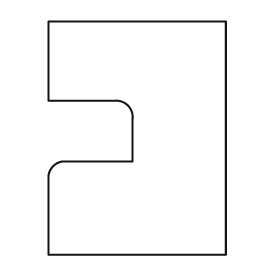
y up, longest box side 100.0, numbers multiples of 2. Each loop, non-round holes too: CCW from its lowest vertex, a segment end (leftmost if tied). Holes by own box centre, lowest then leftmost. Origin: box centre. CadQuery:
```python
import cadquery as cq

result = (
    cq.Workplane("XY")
    .moveTo(-38.0, -50.0)
    .lineTo(38.0, -50.0)
    .lineTo(38.0, 50.0)
    .lineTo(-38.0, 50.0)
    .lineTo(-38.0, 16.0)
    .lineTo(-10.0, 16.0)
    .threePointArc((-4.0, 14.0), (-2.0, 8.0))
    .lineTo(-2.0, -10.0)
    .lineTo(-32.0, -10.0)
    .threePointArc((-36.0, -12.0), (-38.0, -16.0))
    .close()
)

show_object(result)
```